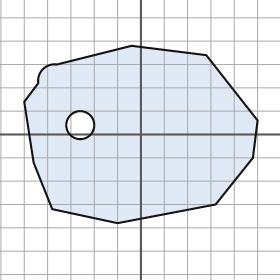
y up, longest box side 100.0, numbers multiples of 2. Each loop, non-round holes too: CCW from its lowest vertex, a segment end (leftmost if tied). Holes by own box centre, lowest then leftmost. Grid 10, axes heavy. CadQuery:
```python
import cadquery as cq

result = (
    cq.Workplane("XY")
    .moveTo(-10.0, -38.0)
    .lineTo(32.0, -30.0)
    .lineTo(48.0, -10.0)
    .lineTo(50.0, 6.0)
    .lineTo(28.0, 34.0)
    .lineTo(-4.0, 38.0)
    .lineTo(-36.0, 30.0)
    .threePointArc((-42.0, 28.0), (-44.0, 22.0))
    .lineTo(-50.0, 14.0)
    .lineTo(-46.0, -12.0)
    .lineTo(-38.0, -32.0)
    .close()
    .moveTo(-26.0, 4.0)
    .circle(6.0)
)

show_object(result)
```